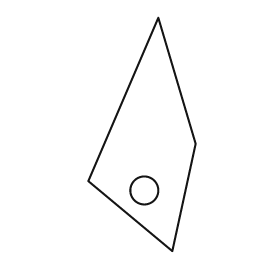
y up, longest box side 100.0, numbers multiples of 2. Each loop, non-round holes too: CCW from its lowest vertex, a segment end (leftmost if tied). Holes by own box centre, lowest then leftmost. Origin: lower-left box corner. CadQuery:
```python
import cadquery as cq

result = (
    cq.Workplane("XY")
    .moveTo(36.0, 0.0)
    .lineTo(46.0, 46.0)
    .lineTo(30.0, 100.0)
    .lineTo(0.0, 30.0)
    .close()
    .moveTo(24.0, 26.0)
    .circle(6.0)
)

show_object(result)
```